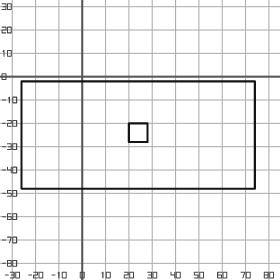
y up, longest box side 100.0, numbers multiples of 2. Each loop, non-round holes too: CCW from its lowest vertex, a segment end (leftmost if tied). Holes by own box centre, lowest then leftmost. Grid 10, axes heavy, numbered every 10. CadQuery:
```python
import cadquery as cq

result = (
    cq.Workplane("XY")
    .moveTo(-26.0, -48.0)
    .lineTo(74.0, -48.0)
    .lineTo(74.0, -2.0)
    .lineTo(-26.0, -2.0)
    .close()
    .moveTo(20.0, -28.0)
    .lineTo(28.0, -28.0)
    .lineTo(28.0, -20.0)
    .lineTo(20.0, -20.0)
    .close()
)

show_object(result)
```